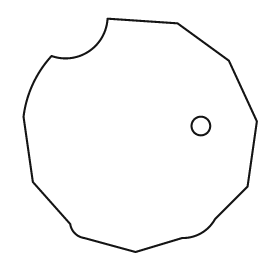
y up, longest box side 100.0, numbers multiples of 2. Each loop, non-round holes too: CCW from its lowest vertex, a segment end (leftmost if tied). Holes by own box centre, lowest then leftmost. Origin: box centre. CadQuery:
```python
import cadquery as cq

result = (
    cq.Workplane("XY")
    .moveTo(-2.0, -50.0)
    .lineTo(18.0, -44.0)
    .threePointArc((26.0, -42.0), (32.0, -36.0))
    .lineTo(46.0, -22.0)
    .lineTo(50.0, 6.0)
    .lineTo(38.0, 32.0)
    .lineTo(16.0, 48.0)
    .lineTo(-14.0, 50.0)
    .threePointArc((-22.0, 36.0), (-38.0, 34.0))
    .threePointArc((-46.0, 22.0), (-50.0, 8.0))
    .lineTo(-46.0, -20.0)
    .lineTo(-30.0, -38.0)
    .threePointArc((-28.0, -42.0), (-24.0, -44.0))
    .close()
    .moveTo(26.0, 4.0)
    .circle(4.0)
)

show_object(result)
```